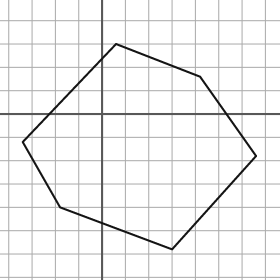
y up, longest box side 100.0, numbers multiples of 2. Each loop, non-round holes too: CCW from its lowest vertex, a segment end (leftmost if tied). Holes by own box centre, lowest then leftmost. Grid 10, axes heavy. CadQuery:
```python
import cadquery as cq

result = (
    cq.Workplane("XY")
    .moveTo(30.0, -58.0)
    .lineTo(66.0, -18.0)
    .lineTo(42.0, 16.0)
    .lineTo(6.0, 30.0)
    .lineTo(-34.0, -12.0)
    .lineTo(-18.0, -40.0)
    .close()
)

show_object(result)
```